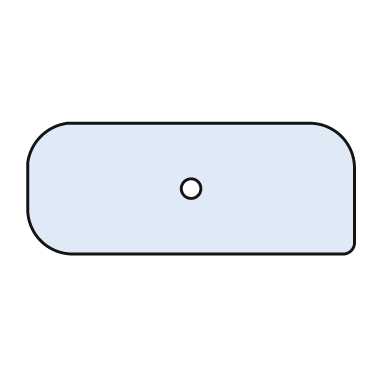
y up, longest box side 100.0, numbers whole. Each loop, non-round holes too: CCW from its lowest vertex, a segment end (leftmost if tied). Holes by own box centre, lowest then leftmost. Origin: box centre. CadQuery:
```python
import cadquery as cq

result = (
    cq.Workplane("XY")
    .moveTo(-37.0, -20.0)
    .lineTo(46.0, -20.0)
    .threePointArc((49.0, -19.0), (50.0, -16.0))
    .lineTo(50.0, 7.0)
    .threePointArc((46.0, 16.0), (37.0, 20.0))
    .lineTo(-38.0, 20.0)
    .threePointArc((-46.0, 16.0), (-50.0, 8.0))
    .lineTo(-50.0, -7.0)
    .threePointArc((-46.0, -16.0), (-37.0, -20.0))
    .close()
    .moveTo(0.0, 0.0)
    .circle(3.0)
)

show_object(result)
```